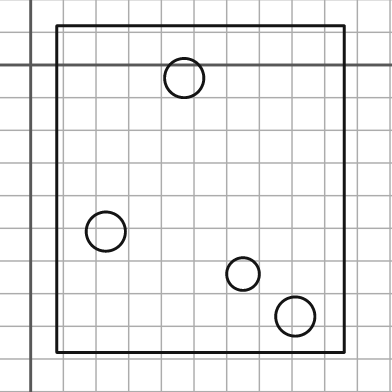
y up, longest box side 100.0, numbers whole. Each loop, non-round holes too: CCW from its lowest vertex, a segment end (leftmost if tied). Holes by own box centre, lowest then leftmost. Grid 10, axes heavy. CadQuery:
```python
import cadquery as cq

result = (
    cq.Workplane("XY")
    .moveTo(8.0, -88.0)
    .lineTo(96.0, -88.0)
    .lineTo(96.0, 12.0)
    .lineTo(8.0, 12.0)
    .close()
    .moveTo(81.0, -77.0)
    .circle(6.0)
    .moveTo(65.0, -64.0)
    .circle(5.0)
    .moveTo(23.0, -51.0)
    .circle(6.0)
    .moveTo(47.0, -4.0)
    .circle(6.0)
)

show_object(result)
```